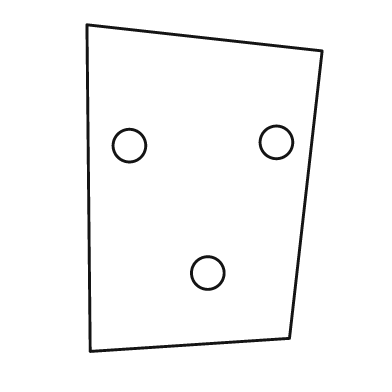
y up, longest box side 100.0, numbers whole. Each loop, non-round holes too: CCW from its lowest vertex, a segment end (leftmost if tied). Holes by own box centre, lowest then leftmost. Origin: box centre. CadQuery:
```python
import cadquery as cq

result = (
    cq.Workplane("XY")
    .moveTo(-35.0, -50.0)
    .lineTo(26.0, -46.0)
    .lineTo(36.0, 42.0)
    .lineTo(-36.0, 50.0)
    .close()
    .moveTo(1.0, -26.0)
    .circle(5.0)
    .moveTo(-23.0, 13.0)
    .circle(5.0)
    .moveTo(22.0, 14.0)
    .circle(5.0)
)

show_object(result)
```